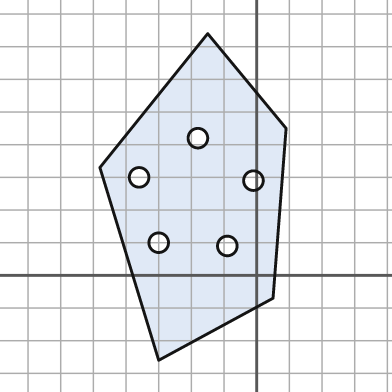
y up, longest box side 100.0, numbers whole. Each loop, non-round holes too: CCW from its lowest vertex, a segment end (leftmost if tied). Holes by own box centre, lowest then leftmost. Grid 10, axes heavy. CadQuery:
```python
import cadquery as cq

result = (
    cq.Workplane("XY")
    .moveTo(-30.0, -26.0)
    .lineTo(5.0, -7.0)
    .lineTo(9.0, 45.0)
    .lineTo(-15.0, 74.0)
    .lineTo(-48.0, 33.0)
    .close()
    .moveTo(-9.0, 9.0)
    .circle(3.0)
    .moveTo(-30.0, 10.0)
    .circle(3.0)
    .moveTo(-1.0, 29.0)
    .circle(3.0)
    .moveTo(-36.0, 30.0)
    .circle(3.0)
    .moveTo(-18.0, 42.0)
    .circle(3.0)
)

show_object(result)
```